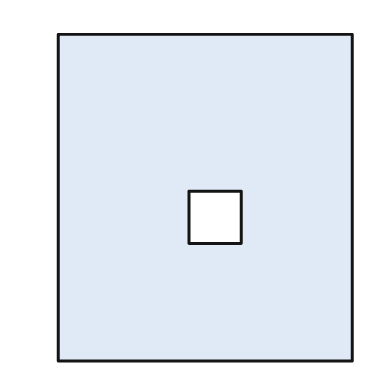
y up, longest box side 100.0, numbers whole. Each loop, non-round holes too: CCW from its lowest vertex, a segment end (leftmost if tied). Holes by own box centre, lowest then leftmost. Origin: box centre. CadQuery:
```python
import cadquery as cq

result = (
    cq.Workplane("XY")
    .moveTo(-45.0, -50.0)
    .lineTo(45.0, -50.0)
    .lineTo(45.0, 50.0)
    .lineTo(-45.0, 50.0)
    .close()
    .moveTo(-5.0, -14.0)
    .lineTo(11.0, -14.0)
    .lineTo(11.0, 2.0)
    .lineTo(-5.0, 2.0)
    .close()
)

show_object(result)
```